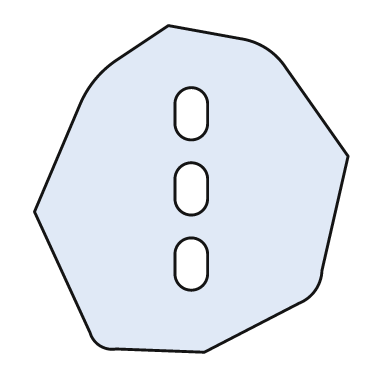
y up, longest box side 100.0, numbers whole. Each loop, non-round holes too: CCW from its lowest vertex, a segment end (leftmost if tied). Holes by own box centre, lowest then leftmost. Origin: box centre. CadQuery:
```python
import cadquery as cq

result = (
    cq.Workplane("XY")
    .moveTo(4.0, -50.0)
    .lineTo(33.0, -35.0)
    .threePointArc((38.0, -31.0), (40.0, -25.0))
    .lineTo(48.0, 10.0)
    .lineTo(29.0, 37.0)
    .threePointArc((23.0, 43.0), (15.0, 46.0))
    .lineTo(-7.0, 50.0)
    .lineTo(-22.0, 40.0)
    .threePointArc((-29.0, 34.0), (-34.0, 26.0))
    .lineTo(-48.0, -7.0)
    .lineTo(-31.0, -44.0)
    .threePointArc((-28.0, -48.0), (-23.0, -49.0))
    .close()
    .moveTo(-5.0, -26.0)
    .threePointArc((0.0, -31.0), (5.0, -26.0))
    .lineTo(5.0, -20.0)
    .threePointArc((0.0, -15.0), (-5.0, -20.0))
    .close()
    .moveTo(-5.0, -3.0)
    .threePointArc((0.0, -8.0), (5.0, -3.0))
    .lineTo(5.0, 3.0)
    .threePointArc((0.0, 8.0), (-5.0, 3.0))
    .close()
    .moveTo(-5.0, 20.0)
    .threePointArc((0.0, 15.0), (5.0, 20.0))
    .lineTo(5.0, 26.0)
    .threePointArc((0.0, 31.0), (-5.0, 26.0))
    .close()
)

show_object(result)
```